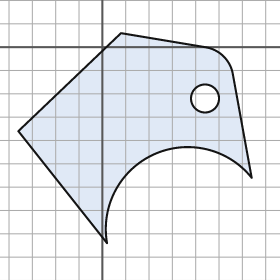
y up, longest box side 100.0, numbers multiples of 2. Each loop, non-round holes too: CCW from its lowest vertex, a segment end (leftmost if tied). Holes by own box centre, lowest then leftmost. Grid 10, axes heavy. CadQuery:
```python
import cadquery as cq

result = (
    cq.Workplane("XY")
    .moveTo(2.0, -84.0)
    .threePointArc((22.0, -46.0), (64.0, -56.0))
    .lineTo(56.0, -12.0)
    .threePointArc((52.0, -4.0), (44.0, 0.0))
    .lineTo(8.0, 6.0)
    .lineTo(-36.0, -36.0)
    .close()
    .moveTo(44.0, -22.0)
    .circle(6.0)
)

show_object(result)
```